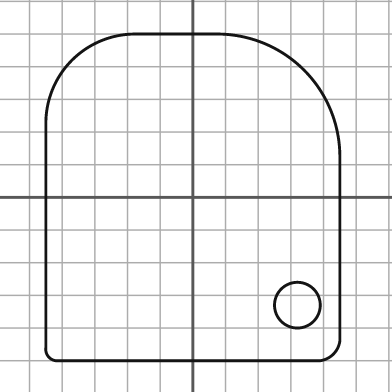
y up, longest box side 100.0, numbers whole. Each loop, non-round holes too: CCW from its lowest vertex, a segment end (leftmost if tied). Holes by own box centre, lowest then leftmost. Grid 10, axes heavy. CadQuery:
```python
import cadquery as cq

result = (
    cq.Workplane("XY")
    .moveTo(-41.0, -50.0)
    .lineTo(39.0, -50.0)
    .threePointArc((43.0, -48.0), (45.0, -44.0))
    .lineTo(45.0, 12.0)
    .threePointArc((34.0, 39.0), (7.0, 50.0))
    .lineTo(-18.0, 50.0)
    .threePointArc((-37.0, 42.0), (-45.0, 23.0))
    .lineTo(-45.0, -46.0)
    .threePointArc((-44.0, -49.0), (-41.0, -50.0))
    .close()
    .moveTo(32.0, -33.0)
    .circle(7.0)
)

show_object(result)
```